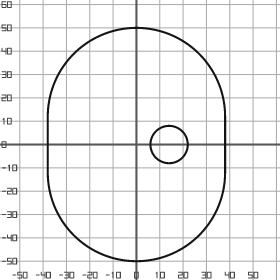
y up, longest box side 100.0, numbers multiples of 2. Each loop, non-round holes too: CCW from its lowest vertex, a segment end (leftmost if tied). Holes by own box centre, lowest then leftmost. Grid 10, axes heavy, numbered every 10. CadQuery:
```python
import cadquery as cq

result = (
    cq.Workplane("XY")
    .moveTo(-38.0, -12.0)
    .threePointArc((0.0, -50.0), (38.0, -12.0))
    .lineTo(38.0, 12.0)
    .threePointArc((0.0, 50.0), (-38.0, 12.0))
    .close()
    .moveTo(14.0, 0.0)
    .circle(8.0)
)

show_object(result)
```